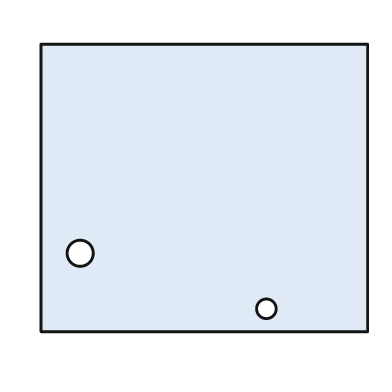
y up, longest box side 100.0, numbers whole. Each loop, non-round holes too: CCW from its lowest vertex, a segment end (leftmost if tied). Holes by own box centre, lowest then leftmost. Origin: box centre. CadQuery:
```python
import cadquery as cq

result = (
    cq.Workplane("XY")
    .moveTo(-50.0, -44.0)
    .lineTo(50.0, -44.0)
    .lineTo(50.0, 44.0)
    .lineTo(-50.0, 44.0)
    .close()
    .moveTo(19.0, -37.0)
    .circle(3.0)
    .moveTo(-38.0, -20.0)
    .circle(4.0)
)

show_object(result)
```